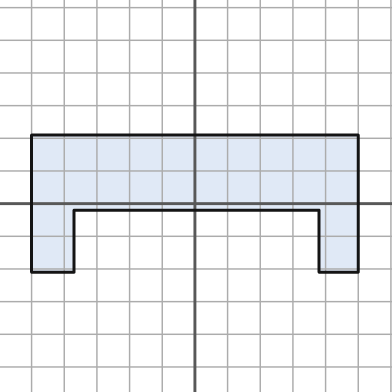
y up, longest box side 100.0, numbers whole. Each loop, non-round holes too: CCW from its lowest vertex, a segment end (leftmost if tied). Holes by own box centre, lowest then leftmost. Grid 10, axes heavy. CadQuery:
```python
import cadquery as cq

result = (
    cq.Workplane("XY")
    .moveTo(-50.0, -21.0)
    .lineTo(-37.0, -21.0)
    .lineTo(-37.0, -2.0)
    .lineTo(38.0, -2.0)
    .lineTo(38.0, -21.0)
    .lineTo(50.0, -21.0)
    .lineTo(50.0, 21.0)
    .lineTo(-50.0, 21.0)
    .close()
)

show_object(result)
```